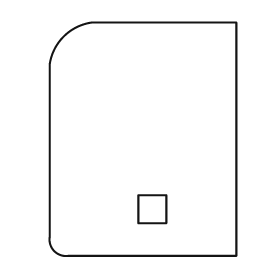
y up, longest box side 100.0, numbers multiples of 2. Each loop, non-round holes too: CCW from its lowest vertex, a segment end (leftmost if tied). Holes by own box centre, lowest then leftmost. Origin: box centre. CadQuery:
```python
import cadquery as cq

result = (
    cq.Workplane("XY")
    .moveTo(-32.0, -50.0)
    .lineTo(40.0, -50.0)
    .lineTo(40.0, 50.0)
    .lineTo(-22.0, 50.0)
    .threePointArc((-34.0, 44.0), (-40.0, 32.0))
    .lineTo(-40.0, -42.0)
    .threePointArc((-38.0, -48.0), (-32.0, -50.0))
    .close()
    .moveTo(-2.0, -36.0)
    .lineTo(10.0, -36.0)
    .lineTo(10.0, -24.0)
    .lineTo(-2.0, -24.0)
    .close()
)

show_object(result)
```